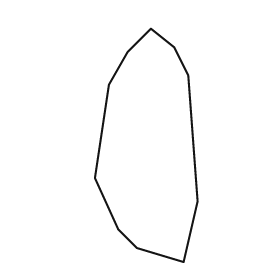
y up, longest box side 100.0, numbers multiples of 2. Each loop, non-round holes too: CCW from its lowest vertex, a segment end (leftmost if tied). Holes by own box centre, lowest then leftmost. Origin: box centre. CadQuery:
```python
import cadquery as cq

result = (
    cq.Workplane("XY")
    .moveTo(16.0, -50.0)
    .lineTo(22.0, -24.0)
    .lineTo(18.0, 30.0)
    .lineTo(12.0, 42.0)
    .lineTo(2.0, 50.0)
    .lineTo(-8.0, 40.0)
    .lineTo(-16.0, 26.0)
    .lineTo(-22.0, -14.0)
    .lineTo(-12.0, -36.0)
    .lineTo(-4.0, -44.0)
    .close()
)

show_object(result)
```